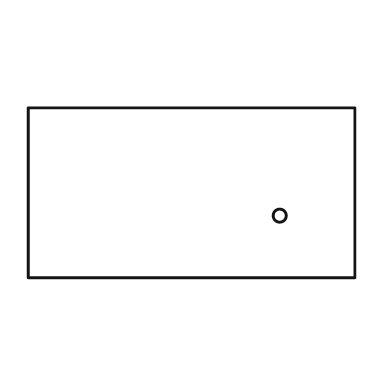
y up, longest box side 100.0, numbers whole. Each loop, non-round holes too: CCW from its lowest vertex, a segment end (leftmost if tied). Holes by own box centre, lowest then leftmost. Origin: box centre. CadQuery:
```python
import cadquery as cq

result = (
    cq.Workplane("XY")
    .moveTo(-50.0, -26.0)
    .lineTo(50.0, -26.0)
    .lineTo(50.0, 26.0)
    .lineTo(-50.0, 26.0)
    .close()
    .moveTo(27.0, -7.0)
    .circle(2.0)
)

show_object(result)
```